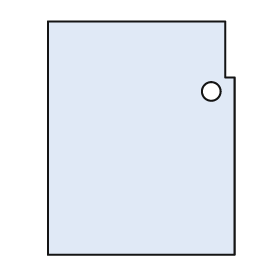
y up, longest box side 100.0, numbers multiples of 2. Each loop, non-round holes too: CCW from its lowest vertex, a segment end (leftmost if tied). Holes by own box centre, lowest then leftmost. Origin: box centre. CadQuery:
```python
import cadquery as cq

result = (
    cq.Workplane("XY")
    .moveTo(-40.0, -50.0)
    .lineTo(40.0, -50.0)
    .lineTo(40.0, 26.0)
    .lineTo(36.0, 26.0)
    .lineTo(36.0, 50.0)
    .lineTo(-40.0, 50.0)
    .close()
    .moveTo(30.0, 20.0)
    .circle(4.0)
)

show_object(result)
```